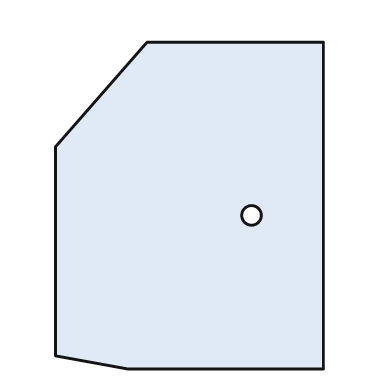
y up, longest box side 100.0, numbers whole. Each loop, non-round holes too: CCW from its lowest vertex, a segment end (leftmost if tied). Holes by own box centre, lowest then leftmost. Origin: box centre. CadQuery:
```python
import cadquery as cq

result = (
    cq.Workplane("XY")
    .moveTo(-19.0, -50.0)
    .lineTo(41.0, -50.0)
    .lineTo(41.0, 50.0)
    .lineTo(-13.0, 50.0)
    .lineTo(-41.0, 18.0)
    .lineTo(-41.0, -46.0)
    .close()
    .moveTo(19.0, -3.0)
    .circle(3.0)
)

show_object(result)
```